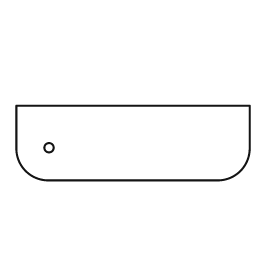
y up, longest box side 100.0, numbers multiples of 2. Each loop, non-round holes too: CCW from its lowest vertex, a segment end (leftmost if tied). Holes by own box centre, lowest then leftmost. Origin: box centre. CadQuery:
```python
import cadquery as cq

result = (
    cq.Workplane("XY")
    .moveTo(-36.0, -16.0)
    .lineTo(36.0, -16.0)
    .threePointArc((46.0, -12.0), (50.0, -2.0))
    .lineTo(50.0, 16.0)
    .lineTo(-50.0, 16.0)
    .lineTo(-50.0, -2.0)
    .threePointArc((-46.0, -12.0), (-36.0, -16.0))
    .close()
    .moveTo(-36.0, -2.0)
    .circle(2.0)
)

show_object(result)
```